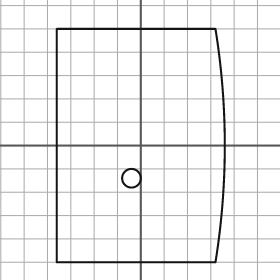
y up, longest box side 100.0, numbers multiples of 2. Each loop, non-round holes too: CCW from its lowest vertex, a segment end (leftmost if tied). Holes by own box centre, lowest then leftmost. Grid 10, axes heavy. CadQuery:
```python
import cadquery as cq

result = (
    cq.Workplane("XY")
    .moveTo(-36.0, -50.0)
    .lineTo(32.0, -50.0)
    .threePointArc((36.0, 0.0), (32.0, 50.0))
    .lineTo(-36.0, 50.0)
    .close()
    .moveTo(-4.0, -14.0)
    .circle(4.0)
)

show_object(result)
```